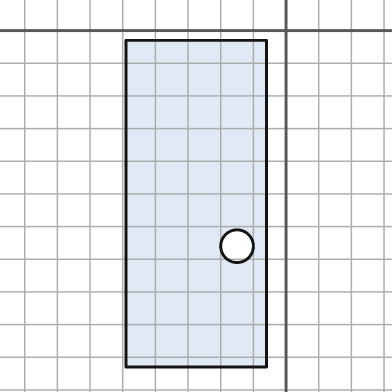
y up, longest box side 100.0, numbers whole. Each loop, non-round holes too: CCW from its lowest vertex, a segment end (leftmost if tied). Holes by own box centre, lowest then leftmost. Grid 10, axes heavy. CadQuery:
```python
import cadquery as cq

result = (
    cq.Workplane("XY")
    .moveTo(-49.0, -103.0)
    .lineTo(-6.0, -103.0)
    .lineTo(-6.0, -3.0)
    .lineTo(-49.0, -3.0)
    .close()
    .moveTo(-15.0, -66.0)
    .circle(5.0)
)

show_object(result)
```